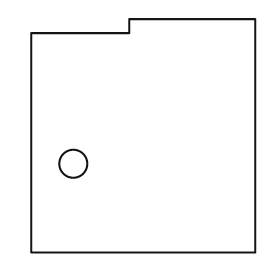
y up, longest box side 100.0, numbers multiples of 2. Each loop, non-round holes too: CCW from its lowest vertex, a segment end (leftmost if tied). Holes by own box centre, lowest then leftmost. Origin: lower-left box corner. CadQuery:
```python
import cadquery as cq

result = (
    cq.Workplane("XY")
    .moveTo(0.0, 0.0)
    .lineTo(96.0, 0.0)
    .lineTo(96.0, 100.0)
    .lineTo(42.0, 100.0)
    .lineTo(42.0, 94.0)
    .lineTo(0.0, 94.0)
    .close()
    .moveTo(18.0, 38.0)
    .circle(6.0)
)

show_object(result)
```